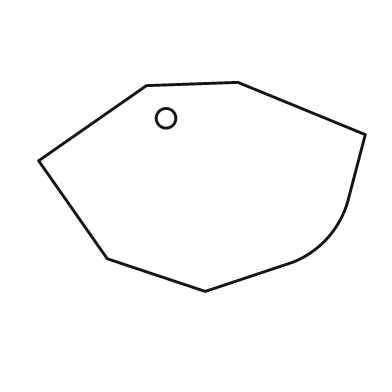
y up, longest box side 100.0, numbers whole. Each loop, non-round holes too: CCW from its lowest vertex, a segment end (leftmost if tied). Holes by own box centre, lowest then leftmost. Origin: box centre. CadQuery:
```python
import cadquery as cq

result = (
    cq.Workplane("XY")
    .moveTo(1.0, -32.0)
    .lineTo(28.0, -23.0)
    .threePointArc((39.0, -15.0), (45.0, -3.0))
    .lineTo(50.0, 16.0)
    .lineTo(11.0, 32.0)
    .lineTo(-17.0, 31.0)
    .lineTo(-50.0, 8.0)
    .lineTo(-29.0, -22.0)
    .close()
    .moveTo(-11.0, 21.0)
    .circle(3.0)
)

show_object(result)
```